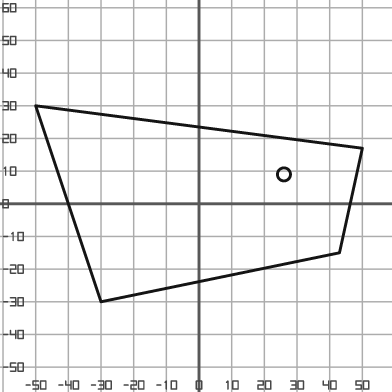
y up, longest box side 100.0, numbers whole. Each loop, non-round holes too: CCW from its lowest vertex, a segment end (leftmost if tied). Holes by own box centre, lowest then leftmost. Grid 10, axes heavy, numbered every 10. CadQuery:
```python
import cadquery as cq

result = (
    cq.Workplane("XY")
    .moveTo(-30.0, -30.0)
    .lineTo(43.0, -15.0)
    .lineTo(50.0, 17.0)
    .lineTo(-50.0, 30.0)
    .close()
    .moveTo(26.0, 9.0)
    .circle(2.0)
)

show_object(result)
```